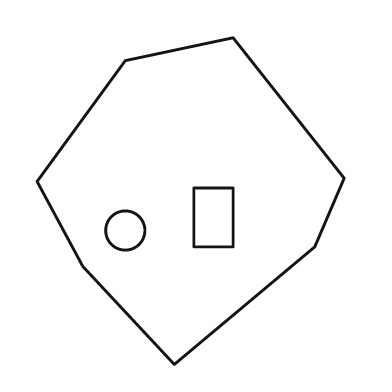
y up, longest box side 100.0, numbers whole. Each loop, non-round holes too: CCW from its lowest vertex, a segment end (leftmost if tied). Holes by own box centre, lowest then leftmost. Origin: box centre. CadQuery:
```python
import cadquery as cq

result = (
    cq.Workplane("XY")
    .moveTo(-5.0, -50.0)
    .lineTo(38.0, -14.0)
    .lineTo(47.0, 7.0)
    .lineTo(13.0, 50.0)
    .lineTo(-20.0, 43.0)
    .lineTo(-47.0, 6.0)
    .lineTo(-33.0, -20.0)
    .close()
    .moveTo(-20.0, -9.0)
    .circle(6.0)
    .moveTo(1.0, -14.0)
    .lineTo(13.0, -14.0)
    .lineTo(13.0, 4.0)
    .lineTo(1.0, 4.0)
    .close()
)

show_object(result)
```